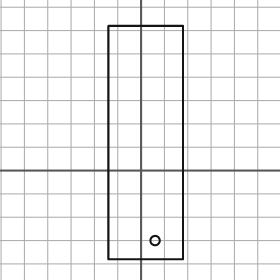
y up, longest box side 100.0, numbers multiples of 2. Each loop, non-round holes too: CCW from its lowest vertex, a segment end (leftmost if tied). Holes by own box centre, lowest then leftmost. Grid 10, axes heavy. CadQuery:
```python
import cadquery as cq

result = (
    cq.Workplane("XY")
    .moveTo(-14.0, -38.0)
    .lineTo(18.0, -38.0)
    .lineTo(18.0, 62.0)
    .lineTo(-14.0, 62.0)
    .close()
    .moveTo(6.0, -30.0)
    .circle(2.0)
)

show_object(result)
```